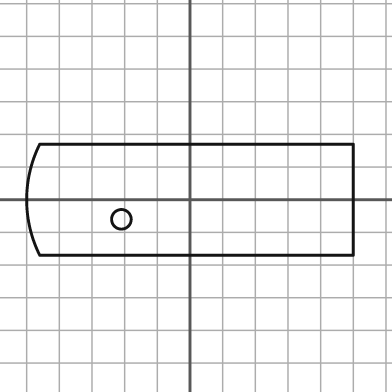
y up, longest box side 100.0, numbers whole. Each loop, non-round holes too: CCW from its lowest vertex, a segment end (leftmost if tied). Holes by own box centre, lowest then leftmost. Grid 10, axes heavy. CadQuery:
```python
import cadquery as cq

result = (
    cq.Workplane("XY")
    .moveTo(-46.0, -17.0)
    .lineTo(50.0, -17.0)
    .lineTo(50.0, 17.0)
    .lineTo(-46.0, 17.0)
    .threePointArc((-50.0, 0.0), (-46.0, -17.0))
    .close()
    .moveTo(-21.0, -6.0)
    .circle(3.0)
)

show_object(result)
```